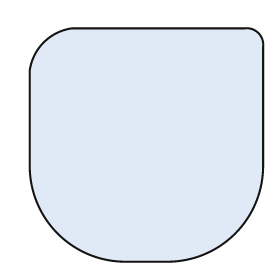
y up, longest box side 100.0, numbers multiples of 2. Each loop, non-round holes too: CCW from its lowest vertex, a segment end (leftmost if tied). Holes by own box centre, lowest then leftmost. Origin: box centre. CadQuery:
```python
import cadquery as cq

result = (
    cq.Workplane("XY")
    .moveTo(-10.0, -50.0)
    .lineTo(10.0, -50.0)
    .threePointArc((38.0, -38.0), (50.0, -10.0))
    .lineTo(50.0, 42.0)
    .threePointArc((48.0, 48.0), (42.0, 50.0))
    .lineTo(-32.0, 50.0)
    .threePointArc((-44.0, 44.0), (-50.0, 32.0))
    .lineTo(-50.0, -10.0)
    .threePointArc((-38.0, -38.0), (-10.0, -50.0))
    .close()
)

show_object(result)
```